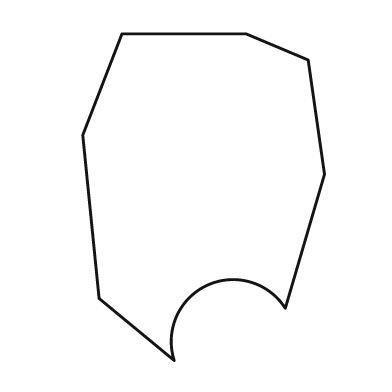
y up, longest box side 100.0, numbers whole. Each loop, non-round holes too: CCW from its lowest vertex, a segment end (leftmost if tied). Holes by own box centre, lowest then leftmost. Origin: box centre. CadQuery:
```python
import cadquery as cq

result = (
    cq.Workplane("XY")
    .moveTo(-9.0, -50.0)
    .threePointArc((1.0, -27.0), (25.0, -34.0))
    .lineTo(37.0, 7.0)
    .lineTo(32.0, 42.0)
    .lineTo(13.0, 50.0)
    .lineTo(-25.0, 50.0)
    .lineTo(-37.0, 19.0)
    .lineTo(-32.0, -31.0)
    .close()
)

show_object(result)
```